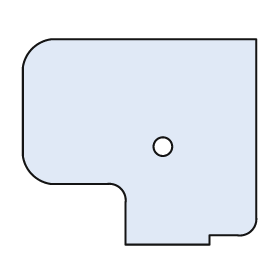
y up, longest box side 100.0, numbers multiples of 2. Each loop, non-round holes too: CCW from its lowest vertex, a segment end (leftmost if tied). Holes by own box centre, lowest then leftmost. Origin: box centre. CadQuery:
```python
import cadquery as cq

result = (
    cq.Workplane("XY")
    .moveTo(-6.0, -44.0)
    .lineTo(30.0, -44.0)
    .lineTo(30.0, -40.0)
    .lineTo(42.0, -40.0)
    .threePointArc((48.0, -38.0), (50.0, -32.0))
    .lineTo(50.0, 44.0)
    .lineTo(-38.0, 44.0)
    .threePointArc((-46.0, 40.0), (-50.0, 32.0))
    .lineTo(-50.0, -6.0)
    .threePointArc((-46.0, -14.0), (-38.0, -18.0))
    .lineTo(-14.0, -18.0)
    .threePointArc((-8.0, -20.0), (-6.0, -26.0))
    .close()
    .moveTo(10.0, -2.0)
    .circle(4.0)
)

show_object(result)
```